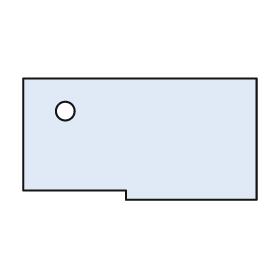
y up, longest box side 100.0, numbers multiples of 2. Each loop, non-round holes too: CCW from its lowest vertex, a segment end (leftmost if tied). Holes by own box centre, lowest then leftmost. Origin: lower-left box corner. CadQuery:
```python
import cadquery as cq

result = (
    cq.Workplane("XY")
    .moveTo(44.0, 0.0)
    .lineTo(100.0, 0.0)
    .lineTo(100.0, 52.0)
    .lineTo(0.0, 52.0)
    .lineTo(0.0, 4.0)
    .lineTo(44.0, 4.0)
    .close()
    .moveTo(18.0, 38.0)
    .circle(4.0)
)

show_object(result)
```